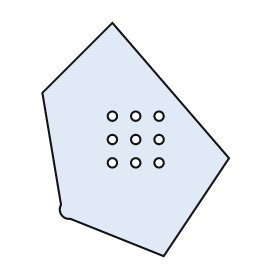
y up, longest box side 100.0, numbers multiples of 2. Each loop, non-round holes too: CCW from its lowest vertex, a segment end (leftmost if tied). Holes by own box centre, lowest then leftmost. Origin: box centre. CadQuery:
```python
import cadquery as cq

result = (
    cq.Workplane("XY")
    .moveTo(12.0, -50.0)
    .lineTo(40.0, -8.0)
    .lineTo(-10.0, 50.0)
    .lineTo(-40.0, 20.0)
    .lineTo(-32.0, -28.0)
    .threePointArc((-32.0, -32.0), (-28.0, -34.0))
    .close()
    .moveTo(-10.0, -10.0)
    .circle(2.0)
    .moveTo(0.0, -10.0)
    .circle(2.0)
    .moveTo(10.0, -10.0)
    .circle(2.0)
    .moveTo(-10.0, 0.0)
    .circle(2.0)
    .moveTo(0.0, 0.0)
    .circle(2.0)
    .moveTo(10.0, 0.0)
    .circle(2.0)
    .moveTo(-10.0, 10.0)
    .circle(2.0)
    .moveTo(0.0, 10.0)
    .circle(2.0)
    .moveTo(10.0, 10.0)
    .circle(2.0)
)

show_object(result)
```